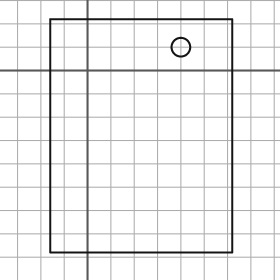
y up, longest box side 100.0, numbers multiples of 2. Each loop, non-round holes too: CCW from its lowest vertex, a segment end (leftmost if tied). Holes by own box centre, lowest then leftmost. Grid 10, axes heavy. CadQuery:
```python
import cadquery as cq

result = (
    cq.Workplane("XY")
    .moveTo(-16.0, -78.0)
    .lineTo(62.0, -78.0)
    .lineTo(62.0, 22.0)
    .lineTo(-16.0, 22.0)
    .close()
    .moveTo(40.0, 10.0)
    .circle(4.0)
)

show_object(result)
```